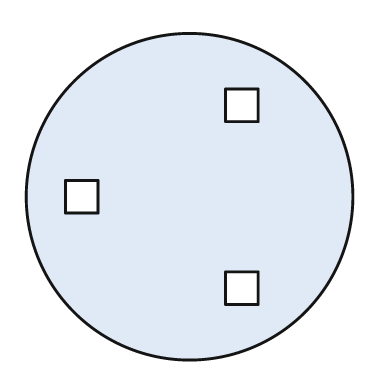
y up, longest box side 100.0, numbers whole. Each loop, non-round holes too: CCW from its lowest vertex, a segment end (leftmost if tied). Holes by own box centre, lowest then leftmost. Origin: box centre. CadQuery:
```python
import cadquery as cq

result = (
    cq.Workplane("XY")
    .moveTo(0.0, 0.0)
    .circle(50.0)
    .moveTo(11.0, -33.0)
    .lineTo(21.0, -33.0)
    .lineTo(21.0, -23.0)
    .lineTo(11.0, -23.0)
    .close()
    .moveTo(-38.0, -5.0)
    .lineTo(-28.0, -5.0)
    .lineTo(-28.0, 5.0)
    .lineTo(-38.0, 5.0)
    .close()
    .moveTo(11.0, 23.0)
    .lineTo(21.0, 23.0)
    .lineTo(21.0, 33.0)
    .lineTo(11.0, 33.0)
    .close()
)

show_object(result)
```